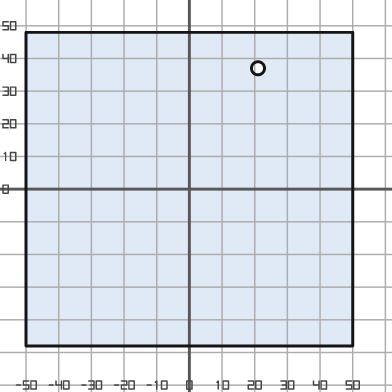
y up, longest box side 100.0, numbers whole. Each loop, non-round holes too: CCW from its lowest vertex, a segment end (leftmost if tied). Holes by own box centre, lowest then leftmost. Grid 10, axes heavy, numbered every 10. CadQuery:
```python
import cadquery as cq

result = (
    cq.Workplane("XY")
    .moveTo(-50.0, -48.0)
    .lineTo(50.0, -48.0)
    .lineTo(50.0, 48.0)
    .lineTo(-50.0, 48.0)
    .close()
    .moveTo(21.0, 37.0)
    .circle(2.0)
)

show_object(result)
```